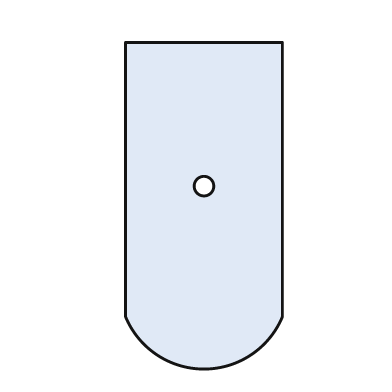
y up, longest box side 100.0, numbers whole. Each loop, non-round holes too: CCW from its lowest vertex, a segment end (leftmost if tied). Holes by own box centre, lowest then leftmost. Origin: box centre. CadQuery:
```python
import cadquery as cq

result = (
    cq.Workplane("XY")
    .moveTo(-24.0, -34.0)
    .threePointArc((0.0, -50.0), (24.0, -34.0))
    .lineTo(24.0, 50.0)
    .lineTo(-24.0, 50.0)
    .close()
    .moveTo(0.0, 6.0)
    .circle(3.0)
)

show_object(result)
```